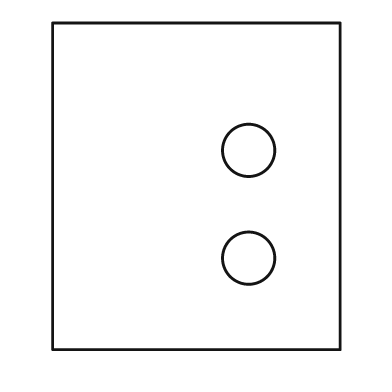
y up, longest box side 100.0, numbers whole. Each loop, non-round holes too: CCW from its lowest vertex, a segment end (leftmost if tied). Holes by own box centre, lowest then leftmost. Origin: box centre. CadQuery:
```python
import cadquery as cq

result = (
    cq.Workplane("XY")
    .moveTo(-44.0, -50.0)
    .lineTo(44.0, -50.0)
    .lineTo(44.0, 50.0)
    .lineTo(-44.0, 50.0)
    .close()
    .moveTo(16.0, -22.0)
    .circle(8.0)
    .moveTo(16.0, 11.0)
    .circle(8.0)
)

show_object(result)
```